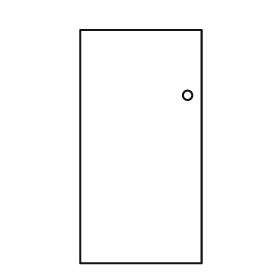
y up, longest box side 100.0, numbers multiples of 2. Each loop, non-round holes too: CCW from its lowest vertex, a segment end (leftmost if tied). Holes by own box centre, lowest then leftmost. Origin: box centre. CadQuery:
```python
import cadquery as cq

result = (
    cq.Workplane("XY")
    .moveTo(-26.0, -50.0)
    .lineTo(26.0, -50.0)
    .lineTo(26.0, 50.0)
    .lineTo(-26.0, 50.0)
    .close()
    .moveTo(20.0, 22.0)
    .circle(2.0)
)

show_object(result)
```